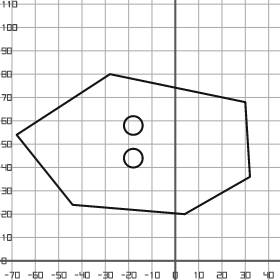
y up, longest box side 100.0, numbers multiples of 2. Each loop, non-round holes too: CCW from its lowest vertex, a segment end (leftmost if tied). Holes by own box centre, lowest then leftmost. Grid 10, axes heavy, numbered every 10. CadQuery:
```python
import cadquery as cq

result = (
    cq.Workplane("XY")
    .moveTo(4.0, 20.0)
    .lineTo(32.0, 36.0)
    .lineTo(30.0, 68.0)
    .lineTo(-28.0, 80.0)
    .lineTo(-68.0, 54.0)
    .lineTo(-44.0, 24.0)
    .close()
    .moveTo(-18.0, 44.0)
    .circle(4.0)
    .moveTo(-18.0, 58.0)
    .circle(4.0)
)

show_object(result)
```